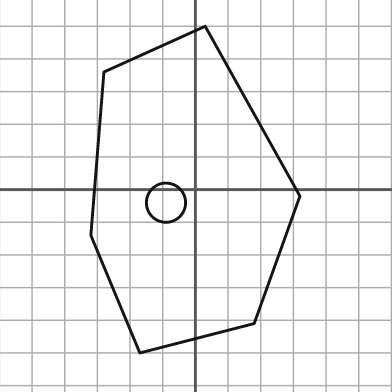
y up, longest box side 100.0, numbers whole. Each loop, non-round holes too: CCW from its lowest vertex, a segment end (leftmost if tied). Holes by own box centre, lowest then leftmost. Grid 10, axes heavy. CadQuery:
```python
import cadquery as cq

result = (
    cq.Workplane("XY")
    .moveTo(-17.0, -50.0)
    .lineTo(18.0, -41.0)
    .lineTo(32.0, -2.0)
    .lineTo(3.0, 50.0)
    .lineTo(-28.0, 36.0)
    .lineTo(-32.0, -14.0)
    .close()
    .moveTo(-9.0, -4.0)
    .circle(6.0)
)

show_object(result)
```